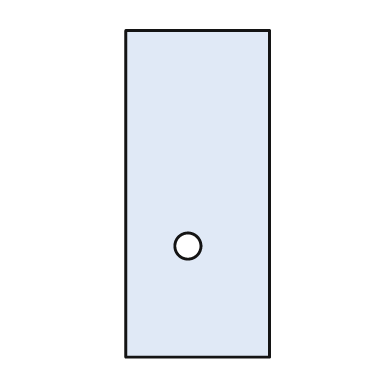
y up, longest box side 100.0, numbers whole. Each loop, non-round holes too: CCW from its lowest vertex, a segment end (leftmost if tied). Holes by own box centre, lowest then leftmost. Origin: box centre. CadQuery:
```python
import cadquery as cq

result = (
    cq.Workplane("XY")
    .moveTo(-22.0, -50.0)
    .lineTo(22.0, -50.0)
    .lineTo(22.0, 50.0)
    .lineTo(-22.0, 50.0)
    .close()
    .moveTo(-3.0, -16.0)
    .circle(4.0)
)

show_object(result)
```